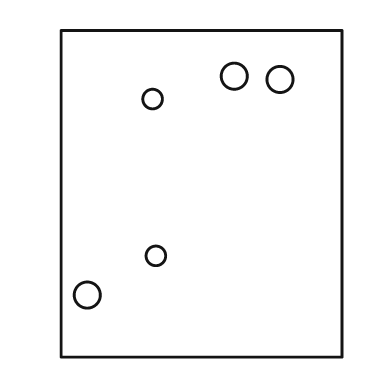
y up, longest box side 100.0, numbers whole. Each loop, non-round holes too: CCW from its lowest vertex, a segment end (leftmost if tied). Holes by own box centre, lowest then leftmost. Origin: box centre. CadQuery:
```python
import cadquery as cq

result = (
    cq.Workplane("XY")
    .moveTo(-43.0, -50.0)
    .lineTo(43.0, -50.0)
    .lineTo(43.0, 50.0)
    .lineTo(-43.0, 50.0)
    .close()
    .moveTo(-35.0, -31.0)
    .circle(4.0)
    .moveTo(-14.0, -19.0)
    .circle(3.0)
    .moveTo(-15.0, 29.0)
    .circle(3.0)
    .moveTo(24.0, 35.0)
    .circle(4.0)
    .moveTo(10.0, 36.0)
    .circle(4.0)
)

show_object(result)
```